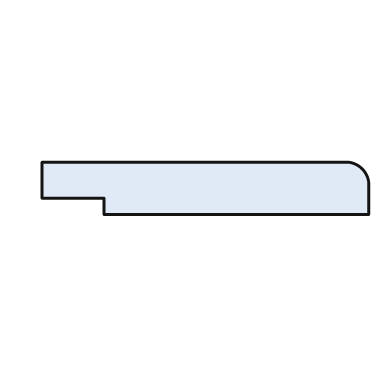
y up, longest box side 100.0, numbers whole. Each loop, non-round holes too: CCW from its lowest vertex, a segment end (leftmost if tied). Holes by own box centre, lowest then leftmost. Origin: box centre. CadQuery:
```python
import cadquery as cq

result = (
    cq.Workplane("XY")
    .moveTo(-31.0, -8.0)
    .lineTo(50.0, -8.0)
    .lineTo(50.0, 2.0)
    .threePointArc((48.0, 6.0), (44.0, 8.0))
    .lineTo(-50.0, 8.0)
    .lineTo(-50.0, -3.0)
    .lineTo(-31.0, -3.0)
    .close()
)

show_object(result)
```